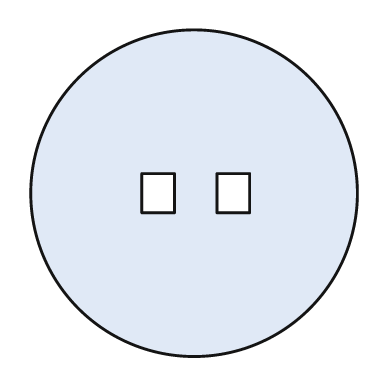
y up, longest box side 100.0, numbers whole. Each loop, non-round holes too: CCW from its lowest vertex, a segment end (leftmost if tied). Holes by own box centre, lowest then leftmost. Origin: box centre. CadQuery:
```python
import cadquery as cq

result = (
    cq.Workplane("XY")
    .moveTo(0.0, 0.0)
    .circle(50.0)
    .moveTo(-16.0, -6.0)
    .lineTo(-6.0, -6.0)
    .lineTo(-6.0, 6.0)
    .lineTo(-16.0, 6.0)
    .close()
    .moveTo(7.0, -6.0)
    .lineTo(17.0, -6.0)
    .lineTo(17.0, 6.0)
    .lineTo(7.0, 6.0)
    .close()
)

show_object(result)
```